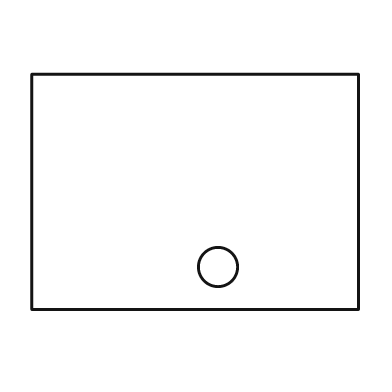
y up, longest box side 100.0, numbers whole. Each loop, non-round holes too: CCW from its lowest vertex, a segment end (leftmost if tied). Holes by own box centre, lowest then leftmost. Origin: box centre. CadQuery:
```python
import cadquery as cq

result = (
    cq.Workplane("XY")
    .moveTo(-50.0, -36.0)
    .lineTo(50.0, -36.0)
    .lineTo(50.0, 36.0)
    .lineTo(-50.0, 36.0)
    .close()
    .moveTo(7.0, -23.0)
    .circle(6.0)
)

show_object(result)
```